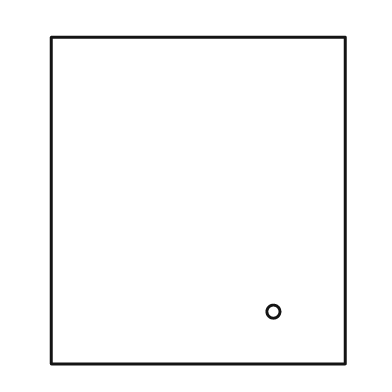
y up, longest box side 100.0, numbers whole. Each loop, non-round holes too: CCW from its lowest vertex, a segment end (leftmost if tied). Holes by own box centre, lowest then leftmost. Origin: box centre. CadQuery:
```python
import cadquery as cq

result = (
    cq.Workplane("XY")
    .moveTo(-45.0, -50.0)
    .lineTo(45.0, -50.0)
    .lineTo(45.0, 50.0)
    .lineTo(-45.0, 50.0)
    .close()
    .moveTo(23.0, -34.0)
    .circle(2.0)
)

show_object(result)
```